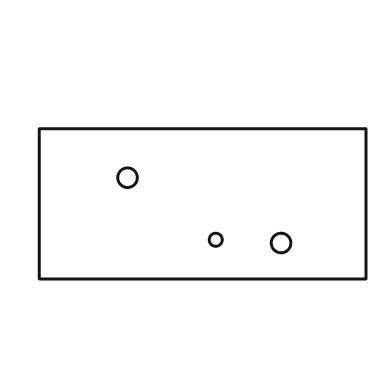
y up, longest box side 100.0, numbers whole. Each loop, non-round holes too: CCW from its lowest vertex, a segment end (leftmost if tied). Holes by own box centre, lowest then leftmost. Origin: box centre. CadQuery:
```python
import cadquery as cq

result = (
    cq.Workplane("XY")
    .moveTo(-50.0, -23.0)
    .lineTo(50.0, -23.0)
    .lineTo(50.0, 23.0)
    .lineTo(-50.0, 23.0)
    .close()
    .moveTo(24.0, -12.0)
    .circle(3.0)
    .moveTo(4.0, -11.0)
    .circle(2.0)
    .moveTo(-23.0, 8.0)
    .circle(3.0)
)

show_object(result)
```